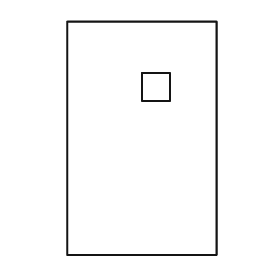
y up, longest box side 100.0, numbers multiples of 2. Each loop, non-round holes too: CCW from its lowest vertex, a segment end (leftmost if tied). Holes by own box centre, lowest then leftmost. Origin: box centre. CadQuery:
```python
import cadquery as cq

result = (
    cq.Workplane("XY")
    .moveTo(-32.0, -50.0)
    .lineTo(32.0, -50.0)
    .lineTo(32.0, 50.0)
    .lineTo(-32.0, 50.0)
    .close()
    .moveTo(0.0, 16.0)
    .lineTo(12.0, 16.0)
    .lineTo(12.0, 28.0)
    .lineTo(0.0, 28.0)
    .close()
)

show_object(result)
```